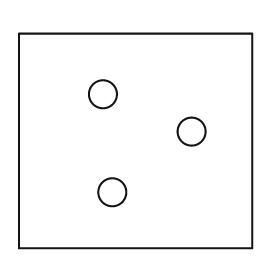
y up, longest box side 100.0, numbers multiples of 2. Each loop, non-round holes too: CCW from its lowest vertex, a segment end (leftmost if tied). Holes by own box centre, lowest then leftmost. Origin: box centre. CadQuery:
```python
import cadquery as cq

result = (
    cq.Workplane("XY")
    .moveTo(-50.0, -46.0)
    .lineTo(50.0, -46.0)
    .lineTo(50.0, 46.0)
    .lineTo(-50.0, 46.0)
    .close()
    .moveTo(-10.0, -22.0)
    .circle(6.0)
    .moveTo(24.0, 4.0)
    .circle(6.0)
    .moveTo(-14.0, 20.0)
    .circle(6.0)
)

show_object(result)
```